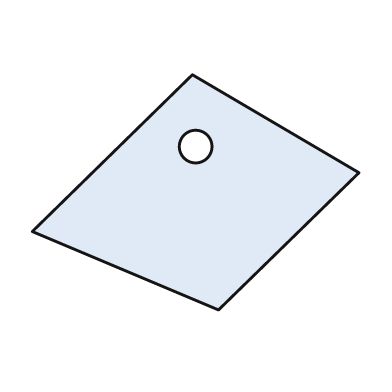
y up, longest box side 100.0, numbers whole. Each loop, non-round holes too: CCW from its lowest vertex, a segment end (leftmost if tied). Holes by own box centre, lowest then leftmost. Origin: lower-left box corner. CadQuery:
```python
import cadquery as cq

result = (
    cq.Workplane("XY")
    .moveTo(57.0, 0.0)
    .lineTo(100.0, 42.0)
    .lineTo(49.0, 72.0)
    .lineTo(0.0, 24.0)
    .close()
    .moveTo(50.0, 50.0)
    .circle(5.0)
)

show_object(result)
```